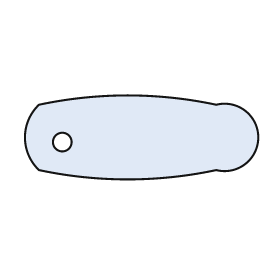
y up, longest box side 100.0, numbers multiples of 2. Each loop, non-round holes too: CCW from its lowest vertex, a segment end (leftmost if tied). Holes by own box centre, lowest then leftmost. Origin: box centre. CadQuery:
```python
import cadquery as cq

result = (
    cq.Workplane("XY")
    .moveTo(-44.0, -14.0)
    .threePointArc((-6.0, -18.0), (32.0, -14.0))
    .threePointArc((50.0, 0.0), (32.0, 14.0))
    .threePointArc((-6.0, 18.0), (-44.0, 14.0))
    .threePointArc((-50.0, 0.0), (-44.0, -14.0))
    .close()
    .moveTo(-34.0, -2.0)
    .circle(4.0)
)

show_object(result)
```